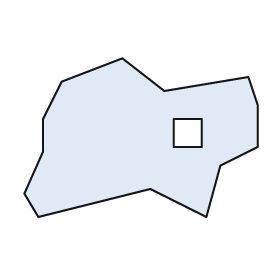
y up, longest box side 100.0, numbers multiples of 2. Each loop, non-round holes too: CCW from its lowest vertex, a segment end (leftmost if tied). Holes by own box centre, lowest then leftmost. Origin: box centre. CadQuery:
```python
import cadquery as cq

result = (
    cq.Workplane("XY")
    .moveTo(-44.0, -34.0)
    .lineTo(4.0, -22.0)
    .lineTo(28.0, -34.0)
    .lineTo(34.0, -12.0)
    .lineTo(50.0, -4.0)
    .lineTo(50.0, 14.0)
    .lineTo(46.0, 26.0)
    .lineTo(10.0, 20.0)
    .lineTo(-8.0, 34.0)
    .lineTo(-34.0, 24.0)
    .lineTo(-42.0, 8.0)
    .lineTo(-42.0, -6.0)
    .lineTo(-50.0, -24.0)
    .close()
    .moveTo(14.0, -4.0)
    .lineTo(26.0, -4.0)
    .lineTo(26.0, 8.0)
    .lineTo(14.0, 8.0)
    .close()
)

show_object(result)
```